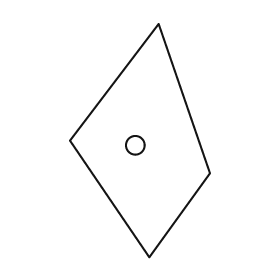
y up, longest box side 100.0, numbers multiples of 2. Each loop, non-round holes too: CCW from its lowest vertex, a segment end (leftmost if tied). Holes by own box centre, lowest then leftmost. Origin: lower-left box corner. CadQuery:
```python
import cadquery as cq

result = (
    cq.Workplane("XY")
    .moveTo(34.0, 0.0)
    .lineTo(60.0, 36.0)
    .lineTo(38.0, 100.0)
    .lineTo(0.0, 50.0)
    .close()
    .moveTo(28.0, 48.0)
    .circle(4.0)
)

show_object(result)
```